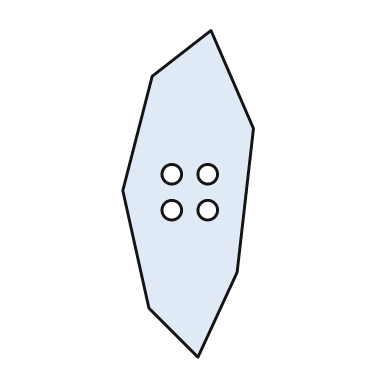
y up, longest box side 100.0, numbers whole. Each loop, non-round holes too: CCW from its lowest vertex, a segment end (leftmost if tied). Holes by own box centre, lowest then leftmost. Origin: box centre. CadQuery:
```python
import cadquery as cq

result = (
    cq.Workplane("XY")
    .moveTo(3.0, -50.0)
    .lineTo(15.0, -24.0)
    .lineTo(20.0, 20.0)
    .lineTo(7.0, 50.0)
    .lineTo(-11.0, 36.0)
    .lineTo(-20.0, 1.0)
    .lineTo(-12.0, -35.0)
    .close()
    .moveTo(-5.0, -5.0)
    .circle(3.0)
    .moveTo(6.0, -5.0)
    .circle(3.0)
    .moveTo(-5.0, 6.0)
    .circle(3.0)
    .moveTo(6.0, 6.0)
    .circle(3.0)
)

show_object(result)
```